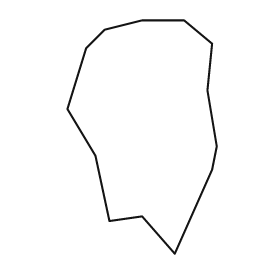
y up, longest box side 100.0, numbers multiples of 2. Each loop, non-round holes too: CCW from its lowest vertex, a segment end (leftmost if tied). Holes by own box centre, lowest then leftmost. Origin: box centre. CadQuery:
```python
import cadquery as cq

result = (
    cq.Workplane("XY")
    .moveTo(14.0, -50.0)
    .lineTo(30.0, -14.0)
    .lineTo(32.0, -4.0)
    .lineTo(28.0, 20.0)
    .lineTo(30.0, 40.0)
    .lineTo(18.0, 50.0)
    .lineTo(0.0, 50.0)
    .lineTo(-16.0, 46.0)
    .lineTo(-24.0, 38.0)
    .lineTo(-32.0, 12.0)
    .lineTo(-20.0, -8.0)
    .lineTo(-14.0, -36.0)
    .lineTo(0.0, -34.0)
    .close()
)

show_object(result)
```